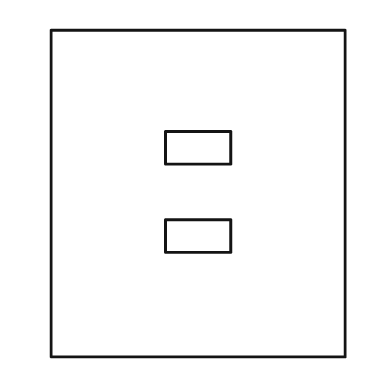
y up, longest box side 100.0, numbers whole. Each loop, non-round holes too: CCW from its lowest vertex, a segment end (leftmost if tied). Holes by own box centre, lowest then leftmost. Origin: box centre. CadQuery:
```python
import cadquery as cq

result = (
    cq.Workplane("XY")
    .moveTo(-45.0, -50.0)
    .lineTo(45.0, -50.0)
    .lineTo(45.0, 50.0)
    .lineTo(-45.0, 50.0)
    .close()
    .moveTo(-10.0, -18.0)
    .lineTo(10.0, -18.0)
    .lineTo(10.0, -8.0)
    .lineTo(-10.0, -8.0)
    .close()
    .moveTo(-10.0, 9.0)
    .lineTo(10.0, 9.0)
    .lineTo(10.0, 19.0)
    .lineTo(-10.0, 19.0)
    .close()
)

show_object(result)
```